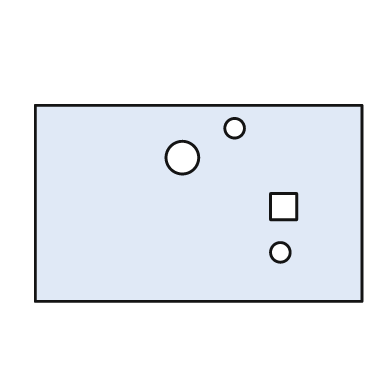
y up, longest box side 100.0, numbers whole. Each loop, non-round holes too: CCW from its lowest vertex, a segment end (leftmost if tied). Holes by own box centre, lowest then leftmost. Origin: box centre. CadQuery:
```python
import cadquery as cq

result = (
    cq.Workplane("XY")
    .moveTo(-50.0, -30.0)
    .lineTo(50.0, -30.0)
    .lineTo(50.0, 30.0)
    .lineTo(-50.0, 30.0)
    .close()
    .moveTo(25.0, -15.0)
    .circle(3.0)
    .moveTo(22.0, -5.0)
    .lineTo(30.0, -5.0)
    .lineTo(30.0, 3.0)
    .lineTo(22.0, 3.0)
    .close()
    .moveTo(-5.0, 14.0)
    .circle(5.0)
    .moveTo(11.0, 23.0)
    .circle(3.0)
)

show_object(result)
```